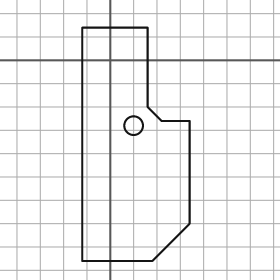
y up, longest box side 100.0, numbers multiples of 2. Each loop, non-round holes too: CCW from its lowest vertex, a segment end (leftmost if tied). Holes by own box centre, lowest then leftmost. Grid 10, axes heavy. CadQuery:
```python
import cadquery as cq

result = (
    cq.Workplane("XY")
    .moveTo(-12.0, -86.0)
    .lineTo(18.0, -86.0)
    .lineTo(34.0, -70.0)
    .lineTo(34.0, -26.0)
    .lineTo(22.0, -26.0)
    .lineTo(16.0, -20.0)
    .lineTo(16.0, 14.0)
    .lineTo(-12.0, 14.0)
    .close()
    .moveTo(10.0, -28.0)
    .circle(4.0)
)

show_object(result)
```